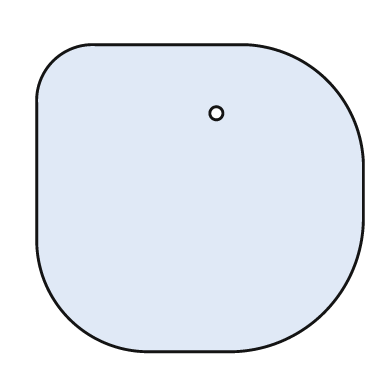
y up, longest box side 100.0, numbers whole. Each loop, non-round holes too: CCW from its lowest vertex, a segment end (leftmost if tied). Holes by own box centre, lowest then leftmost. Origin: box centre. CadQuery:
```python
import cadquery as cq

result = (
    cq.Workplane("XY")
    .moveTo(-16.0, -47.0)
    .lineTo(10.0, -47.0)
    .threePointArc((38.0, -35.0), (50.0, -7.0))
    .lineTo(50.0, 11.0)
    .threePointArc((39.0, 36.0), (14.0, 47.0))
    .lineTo(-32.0, 47.0)
    .threePointArc((-45.0, 42.0), (-50.0, 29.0))
    .lineTo(-50.0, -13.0)
    .threePointArc((-40.0, -37.0), (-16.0, -47.0))
    .close()
    .moveTo(5.0, 26.0)
    .circle(2.0)
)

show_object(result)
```